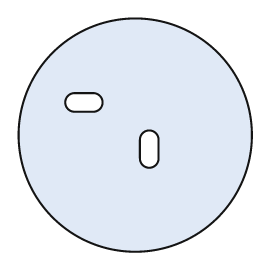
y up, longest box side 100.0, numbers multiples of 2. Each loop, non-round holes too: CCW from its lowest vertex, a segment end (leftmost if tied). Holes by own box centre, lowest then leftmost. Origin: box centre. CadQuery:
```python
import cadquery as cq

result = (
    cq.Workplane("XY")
    .moveTo(0.0, 0.0)
    .circle(50.0)
    .moveTo(2.0, -10.0)
    .threePointArc((6.0, -14.0), (10.0, -10.0))
    .lineTo(10.0, -2.0)
    .threePointArc((6.0, 2.0), (2.0, -2.0))
    .close()
    .moveTo(-26.0, 10.0)
    .lineTo(-18.0, 10.0)
    .threePointArc((-14.0, 14.0), (-18.0, 18.0))
    .lineTo(-26.0, 18.0)
    .threePointArc((-30.0, 14.0), (-26.0, 10.0))
    .close()
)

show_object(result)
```